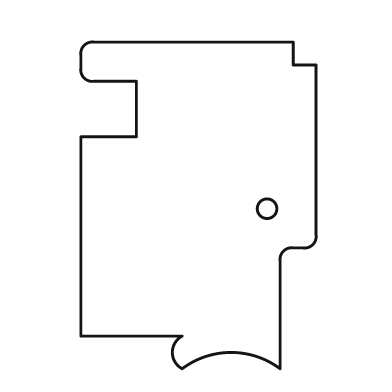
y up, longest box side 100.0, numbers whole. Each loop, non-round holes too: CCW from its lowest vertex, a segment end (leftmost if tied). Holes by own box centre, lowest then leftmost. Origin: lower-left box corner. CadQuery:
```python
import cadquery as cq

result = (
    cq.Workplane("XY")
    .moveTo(31.0, 0.0)
    .threePointArc((46.0, 5.0), (61.0, 0.0))
    .lineTo(61.0, 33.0)
    .threePointArc((62.0, 36.0), (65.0, 37.0))
    .lineTo(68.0, 37.0)
    .threePointArc((71.0, 38.0), (72.0, 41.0))
    .lineTo(72.0, 93.0)
    .lineTo(65.0, 93.0)
    .lineTo(65.0, 100.0)
    .lineTo(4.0, 100.0)
    .threePointArc((1.0, 99.0), (0.0, 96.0))
    .lineTo(0.0, 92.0)
    .threePointArc((1.0, 89.0), (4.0, 88.0))
    .lineTo(17.0, 88.0)
    .lineTo(17.0, 71.0)
    .lineTo(0.0, 71.0)
    .lineTo(0.0, 10.0)
    .lineTo(31.0, 10.0)
    .threePointArc((28.0, 5.0), (31.0, 0.0))
    .close()
    .moveTo(57.0, 49.0)
    .circle(3.0)
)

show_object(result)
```